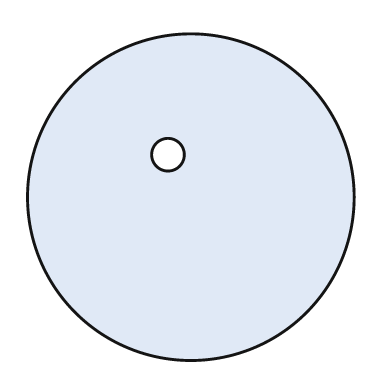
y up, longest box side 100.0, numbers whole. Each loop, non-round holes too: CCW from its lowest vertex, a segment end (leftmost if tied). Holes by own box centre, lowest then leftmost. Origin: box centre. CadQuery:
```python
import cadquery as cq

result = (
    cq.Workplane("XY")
    .moveTo(0.0, 0.0)
    .circle(50.0)
    .moveTo(-7.0, 13.0)
    .circle(5.0)
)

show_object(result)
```